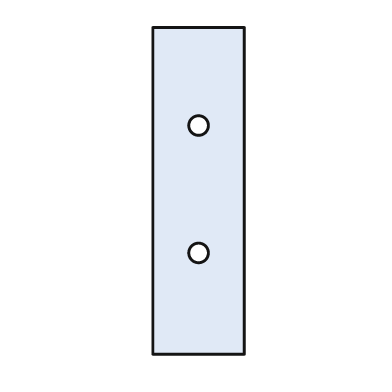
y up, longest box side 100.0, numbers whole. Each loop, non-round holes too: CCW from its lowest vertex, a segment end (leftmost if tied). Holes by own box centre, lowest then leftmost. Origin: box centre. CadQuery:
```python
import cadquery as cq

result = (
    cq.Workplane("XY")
    .moveTo(-14.0, -50.0)
    .lineTo(14.0, -50.0)
    .lineTo(14.0, 50.0)
    .lineTo(-14.0, 50.0)
    .close()
    .moveTo(0.0, -19.0)
    .circle(3.0)
    .moveTo(0.0, 20.0)
    .circle(3.0)
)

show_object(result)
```